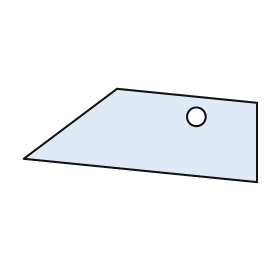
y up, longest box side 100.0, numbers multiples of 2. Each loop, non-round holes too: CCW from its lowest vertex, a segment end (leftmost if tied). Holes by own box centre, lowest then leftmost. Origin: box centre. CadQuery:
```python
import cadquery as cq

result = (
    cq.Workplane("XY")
    .moveTo(50.0, -20.0)
    .lineTo(50.0, 14.0)
    .lineTo(-10.0, 20.0)
    .lineTo(-50.0, -10.0)
    .close()
    .moveTo(24.0, 8.0)
    .circle(4.0)
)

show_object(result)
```